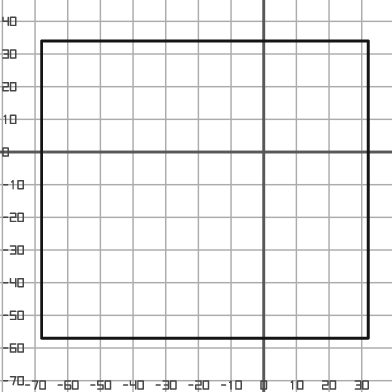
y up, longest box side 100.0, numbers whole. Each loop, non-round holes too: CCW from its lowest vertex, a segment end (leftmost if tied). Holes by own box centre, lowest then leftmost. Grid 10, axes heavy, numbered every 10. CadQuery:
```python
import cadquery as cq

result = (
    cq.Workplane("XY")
    .moveTo(-68.0, -57.0)
    .lineTo(32.0, -57.0)
    .lineTo(32.0, 34.0)
    .lineTo(-68.0, 34.0)
    .close()
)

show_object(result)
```